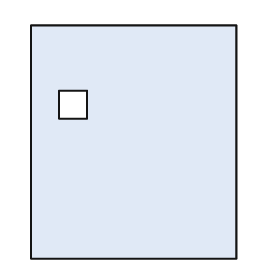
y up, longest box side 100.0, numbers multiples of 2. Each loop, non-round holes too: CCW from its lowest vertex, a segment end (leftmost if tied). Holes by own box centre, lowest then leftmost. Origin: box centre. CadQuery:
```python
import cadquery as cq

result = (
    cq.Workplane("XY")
    .moveTo(-44.0, -50.0)
    .lineTo(44.0, -50.0)
    .lineTo(44.0, 50.0)
    .lineTo(-44.0, 50.0)
    .close()
    .moveTo(-32.0, 10.0)
    .lineTo(-20.0, 10.0)
    .lineTo(-20.0, 22.0)
    .lineTo(-32.0, 22.0)
    .close()
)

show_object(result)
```